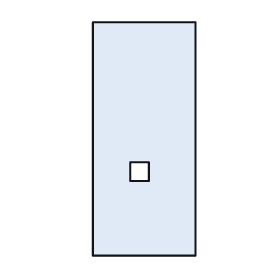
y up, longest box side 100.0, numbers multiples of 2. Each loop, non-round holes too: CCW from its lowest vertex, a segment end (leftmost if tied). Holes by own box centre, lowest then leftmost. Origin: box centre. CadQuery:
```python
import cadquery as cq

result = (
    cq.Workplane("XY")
    .moveTo(-22.0, -50.0)
    .lineTo(22.0, -50.0)
    .lineTo(22.0, 50.0)
    .lineTo(-22.0, 50.0)
    .close()
    .moveTo(-6.0, -18.0)
    .lineTo(2.0, -18.0)
    .lineTo(2.0, -10.0)
    .lineTo(-6.0, -10.0)
    .close()
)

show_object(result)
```